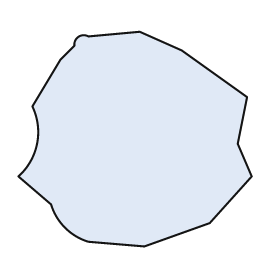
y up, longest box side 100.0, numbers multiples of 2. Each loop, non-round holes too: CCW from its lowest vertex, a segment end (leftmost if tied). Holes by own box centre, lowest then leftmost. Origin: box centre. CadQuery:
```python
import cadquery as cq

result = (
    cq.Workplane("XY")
    .moveTo(4.0, -46.0)
    .lineTo(32.0, -36.0)
    .lineTo(50.0, -16.0)
    .lineTo(44.0, -2.0)
    .lineTo(48.0, 18.0)
    .lineTo(20.0, 38.0)
    .lineTo(2.0, 46.0)
    .lineTo(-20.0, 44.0)
    .threePointArc((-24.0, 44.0), (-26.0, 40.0))
    .lineTo(-32.0, 34.0)
    .lineTo(-44.0, 14.0)
    .threePointArc((-42.0, -2.0), (-50.0, -16.0))
    .lineTo(-36.0, -28.0)
    .threePointArc((-30.0, -38.0), (-20.0, -44.0))
    .close()
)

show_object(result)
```